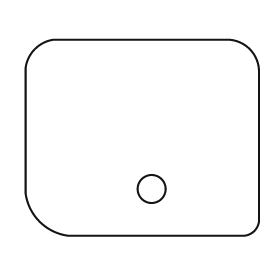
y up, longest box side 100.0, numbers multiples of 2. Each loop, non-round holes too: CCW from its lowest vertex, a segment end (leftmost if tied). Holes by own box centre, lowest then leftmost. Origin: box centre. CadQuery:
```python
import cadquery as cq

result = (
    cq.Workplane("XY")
    .moveTo(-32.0, -42.0)
    .lineTo(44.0, -42.0)
    .threePointArc((48.0, -40.0), (50.0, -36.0))
    .lineTo(50.0, 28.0)
    .threePointArc((46.0, 38.0), (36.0, 42.0))
    .lineTo(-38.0, 42.0)
    .threePointArc((-46.0, 38.0), (-50.0, 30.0))
    .lineTo(-50.0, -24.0)
    .threePointArc((-44.0, -36.0), (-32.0, -42.0))
    .close()
    .moveTo(4.0, -22.0)
    .circle(6.0)
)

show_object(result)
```